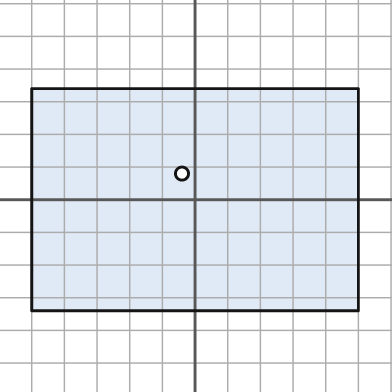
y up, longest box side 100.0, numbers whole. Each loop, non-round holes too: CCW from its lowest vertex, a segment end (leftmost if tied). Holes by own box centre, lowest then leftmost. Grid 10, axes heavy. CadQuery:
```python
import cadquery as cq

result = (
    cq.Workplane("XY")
    .moveTo(-50.0, -34.0)
    .lineTo(50.0, -34.0)
    .lineTo(50.0, 34.0)
    .lineTo(-50.0, 34.0)
    .close()
    .moveTo(-4.0, 8.0)
    .circle(2.0)
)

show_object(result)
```